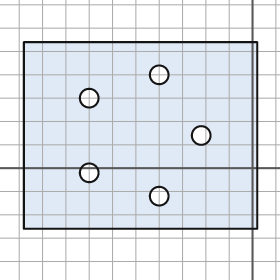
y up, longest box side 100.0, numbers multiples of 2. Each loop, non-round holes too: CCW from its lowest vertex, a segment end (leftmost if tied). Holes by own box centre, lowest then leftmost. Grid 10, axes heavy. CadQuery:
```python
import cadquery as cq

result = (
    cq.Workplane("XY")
    .moveTo(-98.0, -26.0)
    .lineTo(2.0, -26.0)
    .lineTo(2.0, 54.0)
    .lineTo(-98.0, 54.0)
    .close()
    .moveTo(-40.0, -12.0)
    .circle(4.0)
    .moveTo(-70.0, -2.0)
    .circle(4.0)
    .moveTo(-22.0, 14.0)
    .circle(4.0)
    .moveTo(-70.0, 30.0)
    .circle(4.0)
    .moveTo(-40.0, 40.0)
    .circle(4.0)
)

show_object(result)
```